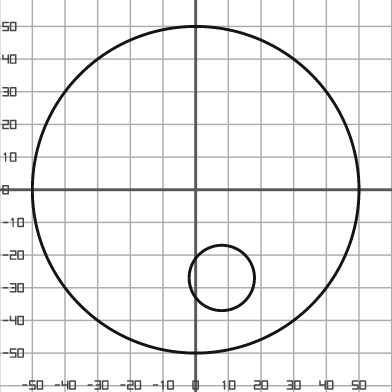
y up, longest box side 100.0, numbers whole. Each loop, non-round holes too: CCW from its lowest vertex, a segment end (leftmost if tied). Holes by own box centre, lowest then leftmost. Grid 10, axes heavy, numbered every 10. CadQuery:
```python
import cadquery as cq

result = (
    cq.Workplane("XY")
    .moveTo(0.0, 0.0)
    .circle(50.0)
    .moveTo(8.0, -27.0)
    .circle(10.0)
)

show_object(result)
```